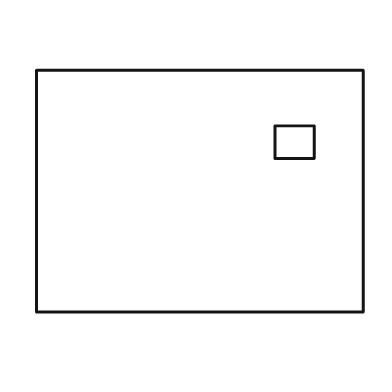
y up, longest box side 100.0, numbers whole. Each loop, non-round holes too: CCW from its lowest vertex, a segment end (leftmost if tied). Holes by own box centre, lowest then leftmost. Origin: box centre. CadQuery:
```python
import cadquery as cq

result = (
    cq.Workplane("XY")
    .moveTo(-50.0, -37.0)
    .lineTo(50.0, -37.0)
    .lineTo(50.0, 37.0)
    .lineTo(-50.0, 37.0)
    .close()
    .moveTo(23.0, 10.0)
    .lineTo(35.0, 10.0)
    .lineTo(35.0, 20.0)
    .lineTo(23.0, 20.0)
    .close()
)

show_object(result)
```